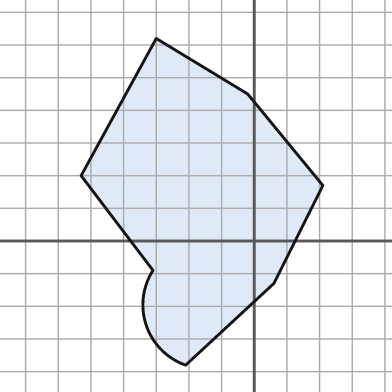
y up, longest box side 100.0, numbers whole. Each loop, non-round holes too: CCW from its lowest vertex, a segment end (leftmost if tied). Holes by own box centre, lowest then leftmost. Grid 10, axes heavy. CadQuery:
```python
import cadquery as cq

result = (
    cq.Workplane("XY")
    .moveTo(-21.0, -38.0)
    .lineTo(6.0, -13.0)
    .lineTo(21.0, 17.0)
    .lineTo(-2.0, 45.0)
    .lineTo(-30.0, 62.0)
    .lineTo(-53.0, 20.0)
    .lineTo(-31.0, -9.0)
    .threePointArc((-33.0, -26.0), (-21.0, -38.0))
    .close()
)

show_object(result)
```